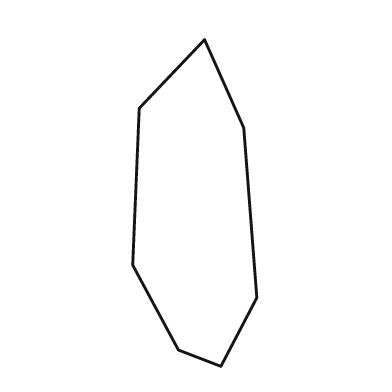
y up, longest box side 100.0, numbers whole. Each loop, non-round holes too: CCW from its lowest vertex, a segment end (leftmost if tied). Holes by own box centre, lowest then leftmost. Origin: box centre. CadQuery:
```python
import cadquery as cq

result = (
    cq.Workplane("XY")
    .moveTo(8.0, -50.0)
    .lineTo(19.0, -29.0)
    .lineTo(15.0, 23.0)
    .lineTo(3.0, 50.0)
    .lineTo(-17.0, 29.0)
    .lineTo(-19.0, -19.0)
    .lineTo(-5.0, -45.0)
    .close()
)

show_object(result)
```